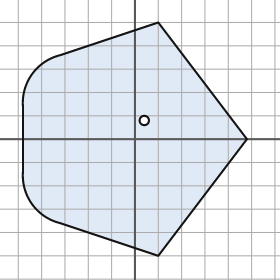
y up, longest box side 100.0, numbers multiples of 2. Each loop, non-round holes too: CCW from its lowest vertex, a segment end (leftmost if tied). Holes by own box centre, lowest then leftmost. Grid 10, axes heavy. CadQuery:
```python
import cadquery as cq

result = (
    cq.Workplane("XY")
    .moveTo(10.0, -50.0)
    .lineTo(48.0, 0.0)
    .lineTo(10.0, 50.0)
    .lineTo(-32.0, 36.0)
    .threePointArc((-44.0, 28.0), (-48.0, 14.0))
    .lineTo(-48.0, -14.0)
    .threePointArc((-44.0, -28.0), (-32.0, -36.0))
    .close()
    .moveTo(4.0, 8.0)
    .circle(2.0)
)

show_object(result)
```